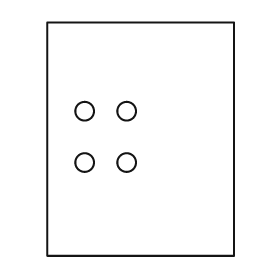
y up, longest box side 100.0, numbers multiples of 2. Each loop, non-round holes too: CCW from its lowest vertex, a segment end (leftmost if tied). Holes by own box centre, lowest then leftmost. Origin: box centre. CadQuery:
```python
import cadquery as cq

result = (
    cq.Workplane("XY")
    .moveTo(-40.0, -50.0)
    .lineTo(40.0, -50.0)
    .lineTo(40.0, 50.0)
    .lineTo(-40.0, 50.0)
    .close()
    .moveTo(-24.0, -10.0)
    .circle(4.0)
    .moveTo(-6.0, -10.0)
    .circle(4.0)
    .moveTo(-24.0, 12.0)
    .circle(4.0)
    .moveTo(-6.0, 12.0)
    .circle(4.0)
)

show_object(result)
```